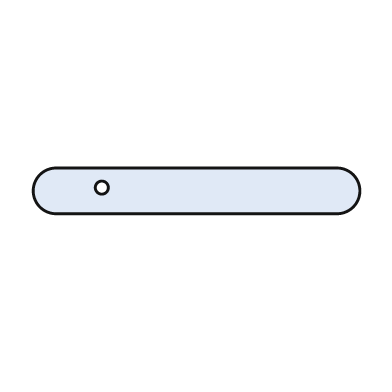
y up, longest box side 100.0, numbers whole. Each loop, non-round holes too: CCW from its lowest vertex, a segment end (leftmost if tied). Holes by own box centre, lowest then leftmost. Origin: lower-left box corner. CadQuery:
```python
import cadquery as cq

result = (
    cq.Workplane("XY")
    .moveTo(7.0, 0.0)
    .lineTo(93.0, 0.0)
    .threePointArc((100.0, 7.0), (93.0, 14.0))
    .lineTo(7.0, 14.0)
    .threePointArc((0.0, 7.0), (7.0, 0.0))
    .close()
    .moveTo(21.0, 8.0)
    .circle(2.0)
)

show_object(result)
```